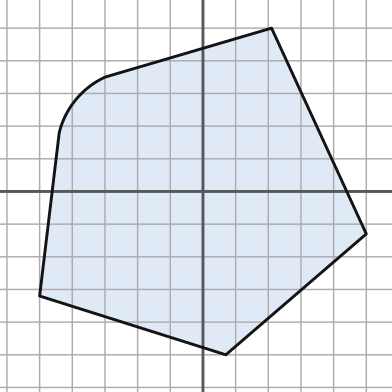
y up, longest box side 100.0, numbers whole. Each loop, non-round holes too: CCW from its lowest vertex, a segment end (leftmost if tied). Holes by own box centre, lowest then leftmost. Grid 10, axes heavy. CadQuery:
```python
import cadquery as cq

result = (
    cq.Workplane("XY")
    .moveTo(7.0, -50.0)
    .lineTo(50.0, -13.0)
    .lineTo(21.0, 50.0)
    .lineTo(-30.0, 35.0)
    .threePointArc((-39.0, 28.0), (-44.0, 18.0))
    .lineTo(-50.0, -32.0)
    .close()
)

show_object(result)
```